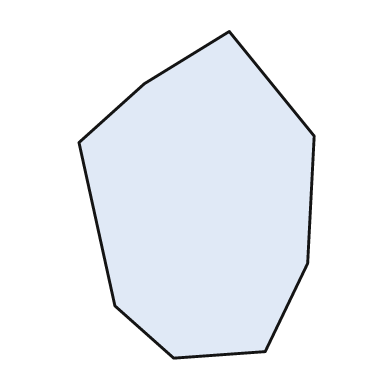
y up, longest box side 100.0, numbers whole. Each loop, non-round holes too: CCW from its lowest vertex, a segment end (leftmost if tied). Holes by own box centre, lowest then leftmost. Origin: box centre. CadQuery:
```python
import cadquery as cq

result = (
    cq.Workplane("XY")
    .moveTo(-7.0, -50.0)
    .lineTo(21.0, -48.0)
    .lineTo(34.0, -21.0)
    .lineTo(36.0, 18.0)
    .lineTo(10.0, 50.0)
    .lineTo(-16.0, 34.0)
    .lineTo(-36.0, 16.0)
    .lineTo(-25.0, -34.0)
    .close()
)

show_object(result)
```